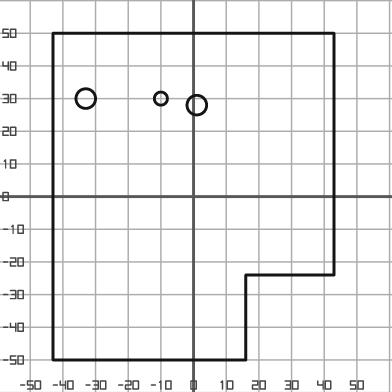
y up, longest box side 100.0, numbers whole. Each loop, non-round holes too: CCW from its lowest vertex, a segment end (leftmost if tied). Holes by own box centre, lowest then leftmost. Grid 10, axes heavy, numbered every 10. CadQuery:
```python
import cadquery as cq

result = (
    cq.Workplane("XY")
    .moveTo(-43.0, -50.0)
    .lineTo(16.0, -50.0)
    .lineTo(16.0, -24.0)
    .lineTo(43.0, -24.0)
    .lineTo(43.0, 50.0)
    .lineTo(-43.0, 50.0)
    .close()
    .moveTo(1.0, 28.0)
    .circle(3.0)
    .moveTo(-33.0, 30.0)
    .circle(3.0)
    .moveTo(-10.0, 30.0)
    .circle(2.0)
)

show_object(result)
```